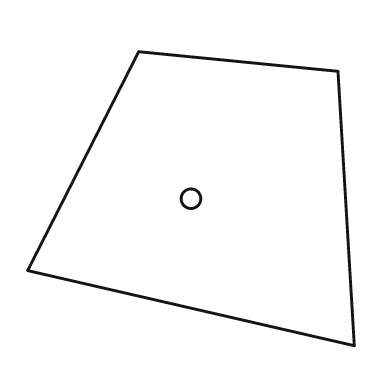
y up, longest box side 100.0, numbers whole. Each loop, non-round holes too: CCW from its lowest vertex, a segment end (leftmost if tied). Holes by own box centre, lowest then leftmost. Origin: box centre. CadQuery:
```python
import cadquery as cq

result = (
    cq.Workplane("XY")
    .moveTo(50.0, -45.0)
    .lineTo(45.0, 39.0)
    .lineTo(-16.0, 45.0)
    .lineTo(-50.0, -22.0)
    .close()
    .moveTo(0.0, 0.0)
    .circle(3.0)
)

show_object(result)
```